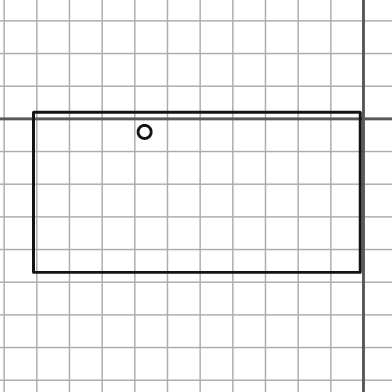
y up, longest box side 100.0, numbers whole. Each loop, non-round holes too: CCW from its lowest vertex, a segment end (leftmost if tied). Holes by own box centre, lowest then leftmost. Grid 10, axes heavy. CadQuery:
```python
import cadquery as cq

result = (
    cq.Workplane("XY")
    .moveTo(-101.0, -47.0)
    .lineTo(-1.0, -47.0)
    .lineTo(-1.0, 2.0)
    .lineTo(-101.0, 2.0)
    .close()
    .moveTo(-67.0, -4.0)
    .circle(2.0)
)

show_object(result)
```